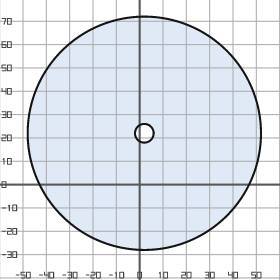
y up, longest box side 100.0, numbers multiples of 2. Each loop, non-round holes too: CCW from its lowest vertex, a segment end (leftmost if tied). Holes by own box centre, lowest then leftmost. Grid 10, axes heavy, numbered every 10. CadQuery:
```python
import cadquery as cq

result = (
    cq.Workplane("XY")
    .moveTo(2.0, 22.0)
    .circle(50.0)
    .moveTo(2.0, 22.0)
    .circle(4.0)
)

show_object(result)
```